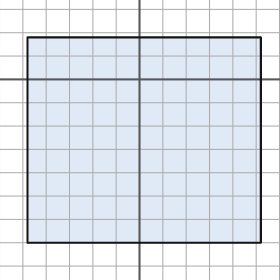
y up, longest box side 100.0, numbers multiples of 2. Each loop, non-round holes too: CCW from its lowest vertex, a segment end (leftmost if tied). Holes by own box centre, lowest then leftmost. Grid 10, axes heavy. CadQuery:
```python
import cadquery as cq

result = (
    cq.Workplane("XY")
    .moveTo(-48.0, -70.0)
    .lineTo(52.0, -70.0)
    .lineTo(52.0, 18.0)
    .lineTo(-48.0, 18.0)
    .close()
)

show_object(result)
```